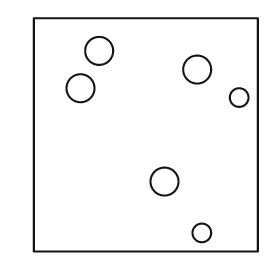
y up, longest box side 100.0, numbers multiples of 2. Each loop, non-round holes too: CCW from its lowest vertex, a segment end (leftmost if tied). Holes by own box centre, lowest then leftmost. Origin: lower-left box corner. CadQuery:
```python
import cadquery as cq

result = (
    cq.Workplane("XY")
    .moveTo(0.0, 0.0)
    .lineTo(96.0, 0.0)
    .lineTo(96.0, 100.0)
    .lineTo(0.0, 100.0)
    .close()
    .moveTo(72.0, 8.0)
    .circle(4.0)
    .moveTo(56.0, 30.0)
    .circle(6.0)
    .moveTo(88.0, 66.0)
    .circle(4.0)
    .moveTo(20.0, 70.0)
    .circle(6.0)
    .moveTo(70.0, 78.0)
    .circle(6.0)
    .moveTo(28.0, 86.0)
    .circle(6.0)
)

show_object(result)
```